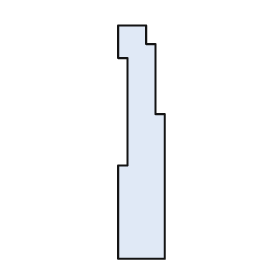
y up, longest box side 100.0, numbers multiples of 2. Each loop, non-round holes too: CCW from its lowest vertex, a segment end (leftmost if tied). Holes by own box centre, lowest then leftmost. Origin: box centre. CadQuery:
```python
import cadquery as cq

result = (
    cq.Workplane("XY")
    .moveTo(-10.0, -50.0)
    .lineTo(10.0, -50.0)
    .lineTo(10.0, 12.0)
    .lineTo(6.0, 12.0)
    .lineTo(6.0, 42.0)
    .lineTo(2.0, 42.0)
    .lineTo(2.0, 50.0)
    .lineTo(-10.0, 50.0)
    .lineTo(-10.0, 36.0)
    .lineTo(-6.0, 36.0)
    .lineTo(-6.0, -10.0)
    .lineTo(-10.0, -10.0)
    .close()
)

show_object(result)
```